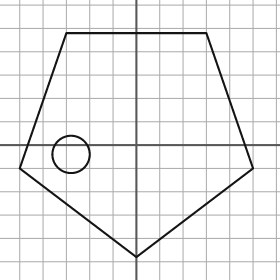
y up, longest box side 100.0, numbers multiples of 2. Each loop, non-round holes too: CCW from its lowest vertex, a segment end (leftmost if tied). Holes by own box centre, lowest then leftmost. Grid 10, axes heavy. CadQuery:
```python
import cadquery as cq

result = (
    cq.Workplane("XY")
    .moveTo(0.0, -48.0)
    .lineTo(50.0, -10.0)
    .lineTo(30.0, 48.0)
    .lineTo(-30.0, 48.0)
    .lineTo(-50.0, -10.0)
    .close()
    .moveTo(-28.0, -4.0)
    .circle(8.0)
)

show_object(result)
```